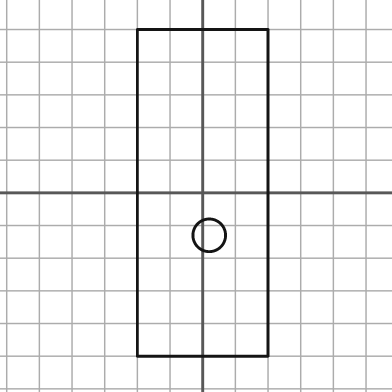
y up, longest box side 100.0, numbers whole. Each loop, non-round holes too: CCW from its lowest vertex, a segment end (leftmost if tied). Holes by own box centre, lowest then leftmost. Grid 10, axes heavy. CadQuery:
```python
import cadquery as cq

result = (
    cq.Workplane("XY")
    .moveTo(-20.0, -50.0)
    .lineTo(20.0, -50.0)
    .lineTo(20.0, 50.0)
    .lineTo(-20.0, 50.0)
    .close()
    .moveTo(2.0, -13.0)
    .circle(5.0)
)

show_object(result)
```